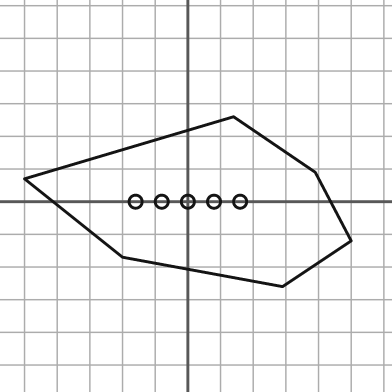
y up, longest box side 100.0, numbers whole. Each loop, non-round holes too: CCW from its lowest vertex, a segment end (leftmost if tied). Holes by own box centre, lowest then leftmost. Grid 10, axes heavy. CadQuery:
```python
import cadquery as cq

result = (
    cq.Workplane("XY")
    .moveTo(29.0, -26.0)
    .lineTo(50.0, -12.0)
    .lineTo(39.0, 9.0)
    .lineTo(14.0, 26.0)
    .lineTo(-50.0, 7.0)
    .lineTo(-20.0, -17.0)
    .close()
    .moveTo(-16.0, 0.0)
    .circle(2.0)
    .moveTo(-8.0, 0.0)
    .circle(2.0)
    .moveTo(0.0, 0.0)
    .circle(2.0)
    .moveTo(8.0, 0.0)
    .circle(2.0)
    .moveTo(16.0, 0.0)
    .circle(2.0)
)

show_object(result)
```